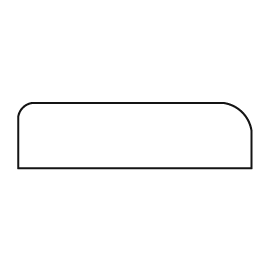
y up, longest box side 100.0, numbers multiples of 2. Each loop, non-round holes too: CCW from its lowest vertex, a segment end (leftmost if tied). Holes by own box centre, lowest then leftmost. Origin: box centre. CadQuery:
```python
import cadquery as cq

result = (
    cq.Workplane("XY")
    .moveTo(-50.0, -14.0)
    .lineTo(50.0, -14.0)
    .lineTo(50.0, 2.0)
    .threePointArc((46.0, 10.0), (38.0, 14.0))
    .lineTo(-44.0, 14.0)
    .threePointArc((-48.0, 12.0), (-50.0, 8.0))
    .close()
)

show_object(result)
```